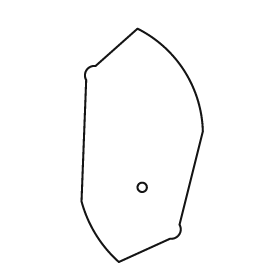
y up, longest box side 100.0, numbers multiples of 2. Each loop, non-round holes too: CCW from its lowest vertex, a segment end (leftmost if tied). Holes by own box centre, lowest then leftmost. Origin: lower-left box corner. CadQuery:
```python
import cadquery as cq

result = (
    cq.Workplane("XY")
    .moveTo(16.0, 0.0)
    .lineTo(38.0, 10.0)
    .threePointArc((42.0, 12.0), (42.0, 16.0))
    .lineTo(52.0, 56.0)
    .threePointArc((44.0, 82.0), (24.0, 100.0))
    .lineTo(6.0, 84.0)
    .threePointArc((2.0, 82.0), (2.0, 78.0))
    .lineTo(0.0, 26.0)
    .threePointArc((6.0, 12.0), (16.0, 0.0))
    .close()
    .moveTo(26.0, 32.0)
    .circle(2.0)
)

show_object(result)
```